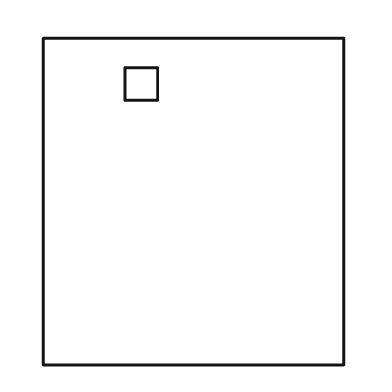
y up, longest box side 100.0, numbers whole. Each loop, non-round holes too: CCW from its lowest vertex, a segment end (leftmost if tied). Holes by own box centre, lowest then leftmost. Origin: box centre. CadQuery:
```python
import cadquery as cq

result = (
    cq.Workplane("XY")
    .moveTo(-46.0, -50.0)
    .lineTo(46.0, -50.0)
    .lineTo(46.0, 50.0)
    .lineTo(-46.0, 50.0)
    .close()
    .moveTo(-21.0, 31.0)
    .lineTo(-11.0, 31.0)
    .lineTo(-11.0, 41.0)
    .lineTo(-21.0, 41.0)
    .close()
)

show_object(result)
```